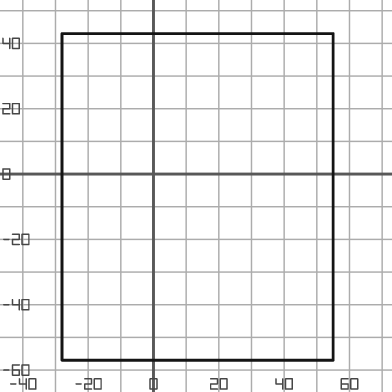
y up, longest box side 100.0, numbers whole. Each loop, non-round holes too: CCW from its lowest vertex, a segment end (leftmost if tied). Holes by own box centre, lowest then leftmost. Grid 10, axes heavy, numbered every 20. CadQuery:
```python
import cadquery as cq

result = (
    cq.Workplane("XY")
    .moveTo(-28.0, -57.0)
    .lineTo(55.0, -57.0)
    .lineTo(55.0, 43.0)
    .lineTo(-28.0, 43.0)
    .close()
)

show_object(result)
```